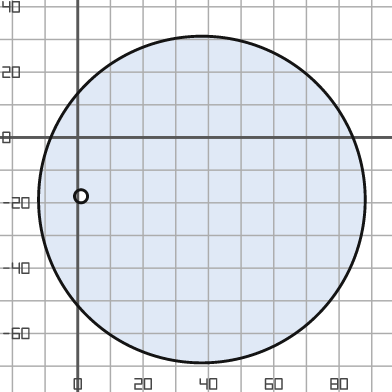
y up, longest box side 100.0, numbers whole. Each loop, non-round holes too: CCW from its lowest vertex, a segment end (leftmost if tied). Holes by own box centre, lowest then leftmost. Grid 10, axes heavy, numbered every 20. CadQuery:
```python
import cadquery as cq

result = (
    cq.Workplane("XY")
    .moveTo(38.0, -19.0)
    .circle(50.0)
    .moveTo(1.0, -18.0)
    .circle(2.0)
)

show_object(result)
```